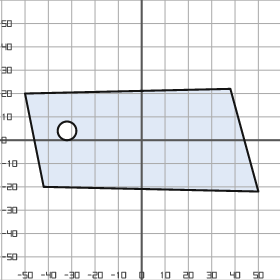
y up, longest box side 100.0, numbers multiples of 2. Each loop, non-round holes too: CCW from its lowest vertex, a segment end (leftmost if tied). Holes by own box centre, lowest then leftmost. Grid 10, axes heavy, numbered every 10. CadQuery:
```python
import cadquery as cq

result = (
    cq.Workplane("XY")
    .moveTo(50.0, -22.0)
    .lineTo(38.0, 22.0)
    .lineTo(-50.0, 20.0)
    .lineTo(-42.0, -20.0)
    .close()
    .moveTo(-32.0, 4.0)
    .circle(4.0)
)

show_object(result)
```